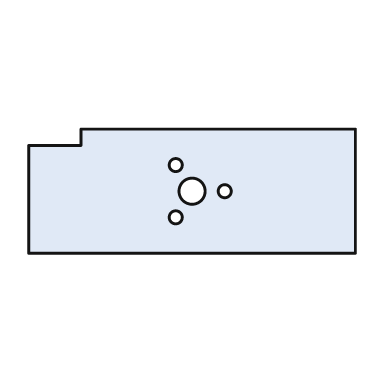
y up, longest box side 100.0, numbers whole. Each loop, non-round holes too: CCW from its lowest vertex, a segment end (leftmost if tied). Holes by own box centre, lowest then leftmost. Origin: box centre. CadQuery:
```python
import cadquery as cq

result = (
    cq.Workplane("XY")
    .moveTo(-50.0, -19.0)
    .lineTo(50.0, -19.0)
    .lineTo(50.0, 19.0)
    .lineTo(-34.0, 19.0)
    .lineTo(-34.0, 14.0)
    .lineTo(-50.0, 14.0)
    .close()
    .moveTo(-5.0, -8.0)
    .circle(2.0)
    .moveTo(0.0, 0.0)
    .circle(4.0)
    .moveTo(10.0, 0.0)
    .circle(2.0)
    .moveTo(-5.0, 8.0)
    .circle(2.0)
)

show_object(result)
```